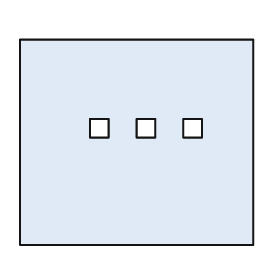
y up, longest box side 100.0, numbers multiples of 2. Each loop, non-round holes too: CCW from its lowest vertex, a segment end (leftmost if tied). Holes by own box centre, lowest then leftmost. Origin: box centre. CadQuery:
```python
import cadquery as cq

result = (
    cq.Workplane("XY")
    .moveTo(-50.0, -44.0)
    .lineTo(50.0, -44.0)
    .lineTo(50.0, 44.0)
    .lineTo(-50.0, 44.0)
    .close()
    .moveTo(-20.0, 2.0)
    .lineTo(-12.0, 2.0)
    .lineTo(-12.0, 10.0)
    .lineTo(-20.0, 10.0)
    .close()
    .moveTo(0.0, 2.0)
    .lineTo(8.0, 2.0)
    .lineTo(8.0, 10.0)
    .lineTo(0.0, 10.0)
    .close()
    .moveTo(20.0, 2.0)
    .lineTo(28.0, 2.0)
    .lineTo(28.0, 10.0)
    .lineTo(20.0, 10.0)
    .close()
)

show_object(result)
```